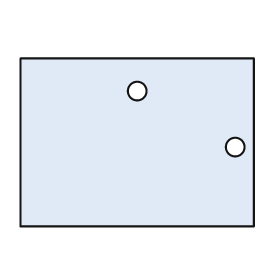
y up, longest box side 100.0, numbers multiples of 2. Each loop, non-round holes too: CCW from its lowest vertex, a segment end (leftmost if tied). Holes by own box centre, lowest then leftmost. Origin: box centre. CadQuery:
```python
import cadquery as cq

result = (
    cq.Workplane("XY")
    .moveTo(-50.0, -36.0)
    .lineTo(50.0, -36.0)
    .lineTo(50.0, 36.0)
    .lineTo(-50.0, 36.0)
    .close()
    .moveTo(42.0, -2.0)
    .circle(4.0)
    .moveTo(0.0, 22.0)
    .circle(4.0)
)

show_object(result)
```